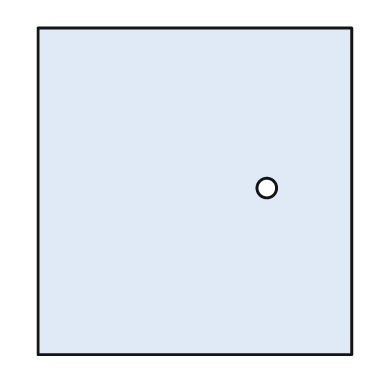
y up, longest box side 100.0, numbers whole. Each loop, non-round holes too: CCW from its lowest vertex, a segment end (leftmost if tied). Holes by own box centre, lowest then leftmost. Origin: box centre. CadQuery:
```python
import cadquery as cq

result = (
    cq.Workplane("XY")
    .moveTo(-48.0, -50.0)
    .lineTo(48.0, -50.0)
    .lineTo(48.0, 50.0)
    .lineTo(-48.0, 50.0)
    .close()
    .moveTo(22.0, 1.0)
    .circle(3.0)
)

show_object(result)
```